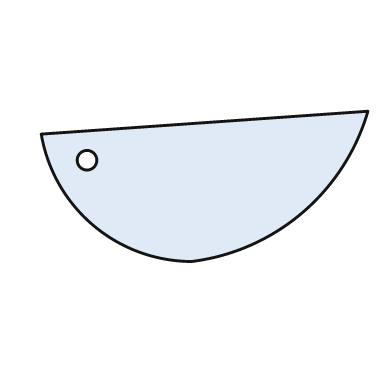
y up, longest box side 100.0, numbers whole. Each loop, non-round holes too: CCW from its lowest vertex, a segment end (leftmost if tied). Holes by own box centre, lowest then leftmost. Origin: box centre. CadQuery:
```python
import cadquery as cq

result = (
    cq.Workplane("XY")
    .moveTo(-4.0, -23.0)
    .threePointArc((30.0, -8.0), (50.0, 23.0))
    .lineTo(-50.0, 16.0)
    .threePointArc((-34.0, -12.0), (-4.0, -23.0))
    .close()
    .moveTo(-36.0, 8.0)
    .circle(3.0)
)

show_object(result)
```